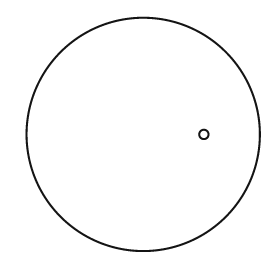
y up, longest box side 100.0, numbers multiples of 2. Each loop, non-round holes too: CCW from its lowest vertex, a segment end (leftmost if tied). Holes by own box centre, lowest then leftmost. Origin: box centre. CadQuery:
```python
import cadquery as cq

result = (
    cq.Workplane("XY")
    .moveTo(0.0, 0.0)
    .circle(50.0)
    .moveTo(26.0, 0.0)
    .circle(2.0)
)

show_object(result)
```